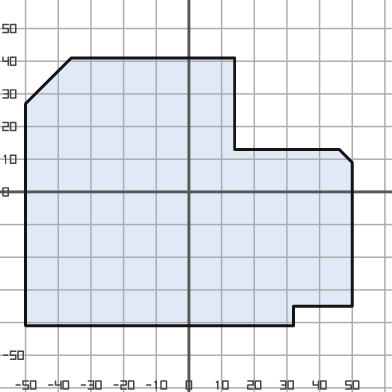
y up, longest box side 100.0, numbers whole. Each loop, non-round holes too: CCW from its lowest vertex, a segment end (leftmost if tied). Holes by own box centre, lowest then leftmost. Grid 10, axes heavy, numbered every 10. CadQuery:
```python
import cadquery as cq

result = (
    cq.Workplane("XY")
    .moveTo(-50.0, -41.0)
    .lineTo(32.0, -41.0)
    .lineTo(32.0, -35.0)
    .lineTo(50.0, -35.0)
    .lineTo(50.0, 9.0)
    .lineTo(46.0, 13.0)
    .lineTo(14.0, 13.0)
    .lineTo(14.0, 41.0)
    .lineTo(-36.0, 41.0)
    .lineTo(-50.0, 27.0)
    .close()
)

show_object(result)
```